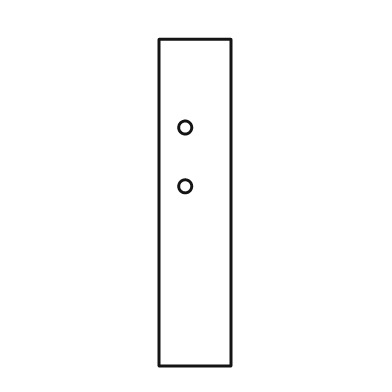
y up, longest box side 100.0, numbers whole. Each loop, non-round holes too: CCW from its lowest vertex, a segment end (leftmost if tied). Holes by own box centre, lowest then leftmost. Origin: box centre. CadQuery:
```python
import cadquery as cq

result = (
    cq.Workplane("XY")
    .moveTo(-11.0, -50.0)
    .lineTo(11.0, -50.0)
    .lineTo(11.0, 50.0)
    .lineTo(-11.0, 50.0)
    .close()
    .moveTo(-3.0, 5.0)
    .circle(2.0)
    .moveTo(-3.0, 23.0)
    .circle(2.0)
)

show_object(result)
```